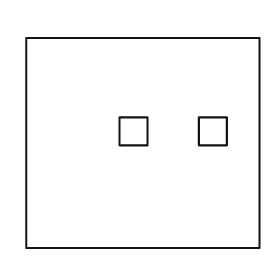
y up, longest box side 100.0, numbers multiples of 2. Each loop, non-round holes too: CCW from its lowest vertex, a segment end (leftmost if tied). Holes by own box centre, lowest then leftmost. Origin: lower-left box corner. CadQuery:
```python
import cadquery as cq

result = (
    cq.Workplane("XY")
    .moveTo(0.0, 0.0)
    .lineTo(100.0, 0.0)
    .lineTo(100.0, 90.0)
    .lineTo(0.0, 90.0)
    .close()
    .moveTo(40.0, 44.0)
    .lineTo(52.0, 44.0)
    .lineTo(52.0, 56.0)
    .lineTo(40.0, 56.0)
    .close()
    .moveTo(74.0, 44.0)
    .lineTo(86.0, 44.0)
    .lineTo(86.0, 56.0)
    .lineTo(74.0, 56.0)
    .close()
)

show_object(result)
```